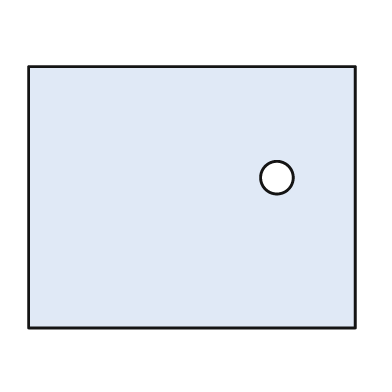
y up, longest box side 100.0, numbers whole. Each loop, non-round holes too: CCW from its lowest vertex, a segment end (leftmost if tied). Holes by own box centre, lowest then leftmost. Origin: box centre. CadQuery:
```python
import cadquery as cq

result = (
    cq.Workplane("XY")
    .moveTo(-50.0, -40.0)
    .lineTo(50.0, -40.0)
    .lineTo(50.0, 40.0)
    .lineTo(-50.0, 40.0)
    .close()
    .moveTo(26.0, 6.0)
    .circle(5.0)
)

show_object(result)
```